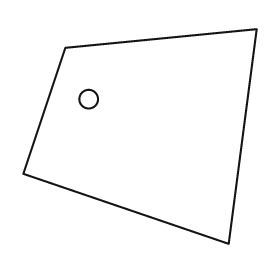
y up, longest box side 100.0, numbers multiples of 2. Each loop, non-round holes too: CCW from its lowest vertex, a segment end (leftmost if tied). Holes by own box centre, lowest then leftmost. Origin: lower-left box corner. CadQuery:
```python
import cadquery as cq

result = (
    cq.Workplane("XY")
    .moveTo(88.0, 0.0)
    .lineTo(100.0, 92.0)
    .lineTo(18.0, 84.0)
    .lineTo(0.0, 30.0)
    .close()
    .moveTo(28.0, 62.0)
    .circle(4.0)
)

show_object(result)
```